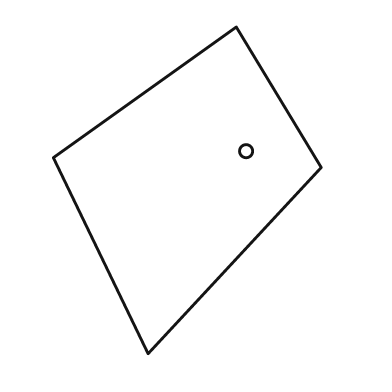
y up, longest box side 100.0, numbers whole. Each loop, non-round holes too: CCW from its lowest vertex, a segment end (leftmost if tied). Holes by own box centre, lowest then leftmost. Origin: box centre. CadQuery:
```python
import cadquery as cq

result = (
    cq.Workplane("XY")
    .moveTo(-12.0, -50.0)
    .lineTo(41.0, 7.0)
    .lineTo(15.0, 50.0)
    .lineTo(-41.0, 10.0)
    .close()
    .moveTo(18.0, 12.0)
    .circle(2.0)
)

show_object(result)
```